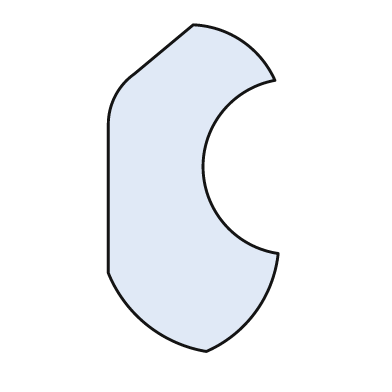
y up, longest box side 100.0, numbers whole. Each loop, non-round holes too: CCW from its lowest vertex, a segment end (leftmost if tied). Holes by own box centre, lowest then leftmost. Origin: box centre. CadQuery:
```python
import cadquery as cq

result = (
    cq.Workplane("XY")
    .moveTo(4.0, -50.0)
    .threePointArc((19.0, -38.0), (26.0, -20.0))
    .threePointArc((3.0, 6.0), (25.0, 33.0))
    .threePointArc((15.0, 45.0), (0.0, 50.0))
    .lineTo(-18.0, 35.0)
    .threePointArc((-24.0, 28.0), (-26.0, 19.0))
    .lineTo(-26.0, -26.0)
    .threePointArc((-14.0, -42.0), (4.0, -50.0))
    .close()
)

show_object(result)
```